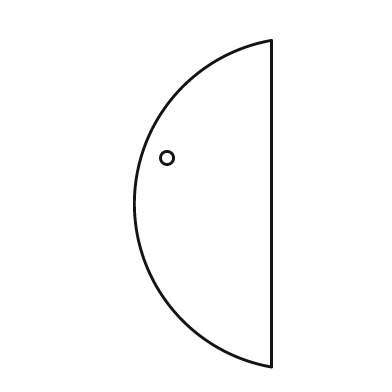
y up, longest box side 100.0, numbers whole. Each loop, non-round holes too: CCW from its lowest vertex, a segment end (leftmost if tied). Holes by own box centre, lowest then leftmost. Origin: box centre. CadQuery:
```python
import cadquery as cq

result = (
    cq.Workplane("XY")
    .moveTo(21.0, -50.0)
    .lineTo(21.0, 50.0)
    .threePointArc((-21.0, 0.0), (21.0, -50.0))
    .close()
    .moveTo(-11.0, 14.0)
    .circle(2.0)
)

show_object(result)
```